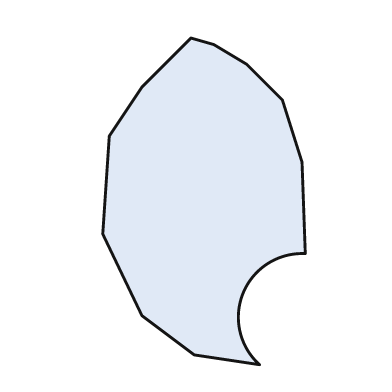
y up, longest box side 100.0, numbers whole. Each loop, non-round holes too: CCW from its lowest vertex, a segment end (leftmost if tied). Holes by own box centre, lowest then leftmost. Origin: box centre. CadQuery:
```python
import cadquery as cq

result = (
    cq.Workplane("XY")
    .moveTo(17.0, -50.0)
    .threePointArc((12.0, -28.0), (31.0, -16.0))
    .lineTo(30.0, 12.0)
    .lineTo(24.0, 31.0)
    .lineTo(13.0, 42.0)
    .lineTo(3.0, 48.0)
    .lineTo(-4.0, 50.0)
    .lineTo(-19.0, 35.0)
    .lineTo(-29.0, 20.0)
    .lineTo(-31.0, -10.0)
    .lineTo(-19.0, -35.0)
    .lineTo(-3.0, -47.0)
    .close()
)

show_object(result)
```